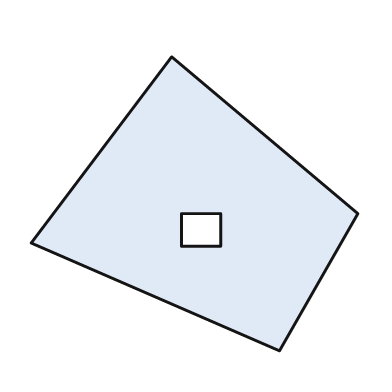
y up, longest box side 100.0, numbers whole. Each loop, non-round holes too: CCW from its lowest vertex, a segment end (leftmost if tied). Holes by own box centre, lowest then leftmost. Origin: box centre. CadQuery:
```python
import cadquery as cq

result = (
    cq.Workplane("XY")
    .moveTo(26.0, -45.0)
    .lineTo(50.0, -3.0)
    .lineTo(-7.0, 45.0)
    .lineTo(-50.0, -12.0)
    .close()
    .moveTo(-4.0, -13.0)
    .lineTo(8.0, -13.0)
    .lineTo(8.0, -3.0)
    .lineTo(-4.0, -3.0)
    .close()
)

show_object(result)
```